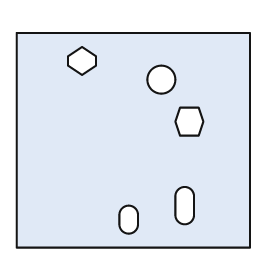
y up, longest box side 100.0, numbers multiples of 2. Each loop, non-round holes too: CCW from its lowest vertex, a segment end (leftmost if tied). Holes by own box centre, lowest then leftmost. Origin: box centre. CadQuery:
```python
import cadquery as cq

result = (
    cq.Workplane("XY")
    .moveTo(-50.0, -46.0)
    .lineTo(50.0, -46.0)
    .lineTo(50.0, 46.0)
    .lineTo(-50.0, 46.0)
    .close()
    .moveTo(-6.0, -36.0)
    .threePointArc((-2.0, -40.0), (2.0, -36.0))
    .lineTo(2.0, -32.0)
    .threePointArc((-2.0, -28.0), (-6.0, -32.0))
    .close()
    .moveTo(18.0, -32.0)
    .threePointArc((22.0, -36.0), (26.0, -32.0))
    .lineTo(26.0, -24.0)
    .threePointArc((22.0, -20.0), (18.0, -24.0))
    .close()
    .moveTo(20.0, 2.0)
    .lineTo(28.0, 2.0)
    .lineTo(30.0, 8.0)
    .lineTo(28.0, 14.0)
    .lineTo(20.0, 14.0)
    .lineTo(18.0, 8.0)
    .close()
    .moveTo(12.0, 26.0)
    .circle(6.0)
    .moveTo(-22.0, 28.0)
    .lineTo(-16.0, 32.0)
    .lineTo(-16.0, 36.0)
    .lineTo(-22.0, 40.0)
    .lineTo(-28.0, 36.0)
    .lineTo(-28.0, 32.0)
    .close()
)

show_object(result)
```